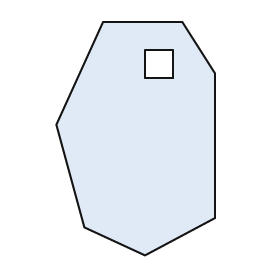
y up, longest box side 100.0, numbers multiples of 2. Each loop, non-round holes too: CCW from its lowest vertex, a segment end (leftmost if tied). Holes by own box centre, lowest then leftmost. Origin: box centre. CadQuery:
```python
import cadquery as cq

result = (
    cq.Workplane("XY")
    .moveTo(4.0, -50.0)
    .lineTo(34.0, -34.0)
    .lineTo(34.0, 28.0)
    .lineTo(20.0, 50.0)
    .lineTo(-14.0, 50.0)
    .lineTo(-34.0, 6.0)
    .lineTo(-22.0, -38.0)
    .close()
    .moveTo(4.0, 26.0)
    .lineTo(16.0, 26.0)
    .lineTo(16.0, 38.0)
    .lineTo(4.0, 38.0)
    .close()
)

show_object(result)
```